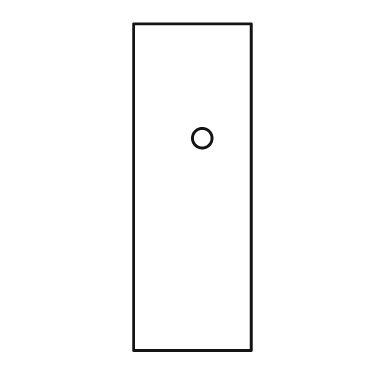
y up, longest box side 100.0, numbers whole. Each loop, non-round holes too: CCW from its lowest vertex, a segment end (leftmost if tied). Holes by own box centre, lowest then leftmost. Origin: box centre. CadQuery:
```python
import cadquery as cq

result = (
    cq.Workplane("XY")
    .moveTo(-18.0, -50.0)
    .lineTo(18.0, -50.0)
    .lineTo(18.0, 50.0)
    .lineTo(-18.0, 50.0)
    .close()
    .moveTo(3.0, 15.0)
    .circle(3.0)
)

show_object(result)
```